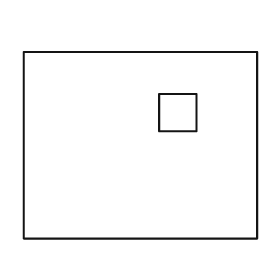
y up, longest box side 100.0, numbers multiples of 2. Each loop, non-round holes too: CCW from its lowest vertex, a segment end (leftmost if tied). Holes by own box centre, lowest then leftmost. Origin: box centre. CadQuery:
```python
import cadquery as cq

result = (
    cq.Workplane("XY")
    .moveTo(-50.0, -40.0)
    .lineTo(50.0, -40.0)
    .lineTo(50.0, 40.0)
    .lineTo(-50.0, 40.0)
    .close()
    .moveTo(8.0, 6.0)
    .lineTo(24.0, 6.0)
    .lineTo(24.0, 22.0)
    .lineTo(8.0, 22.0)
    .close()
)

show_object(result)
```